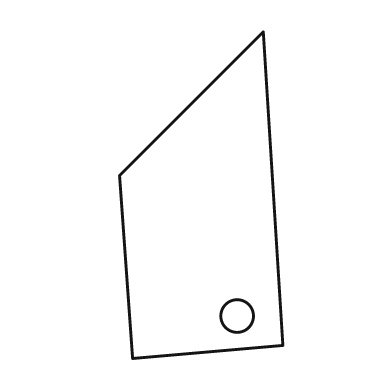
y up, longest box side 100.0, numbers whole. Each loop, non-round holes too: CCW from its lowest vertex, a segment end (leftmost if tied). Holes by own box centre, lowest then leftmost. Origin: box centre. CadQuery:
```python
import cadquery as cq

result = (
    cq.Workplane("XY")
    .moveTo(-21.0, -50.0)
    .lineTo(25.0, -46.0)
    .lineTo(19.0, 50.0)
    .lineTo(-25.0, 6.0)
    .close()
    .moveTo(11.0, -37.0)
    .circle(5.0)
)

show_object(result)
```